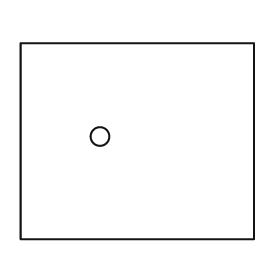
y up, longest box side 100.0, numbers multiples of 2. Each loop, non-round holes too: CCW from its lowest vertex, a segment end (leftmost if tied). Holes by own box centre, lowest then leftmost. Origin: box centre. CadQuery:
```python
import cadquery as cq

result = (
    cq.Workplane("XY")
    .moveTo(-50.0, -42.0)
    .lineTo(50.0, -42.0)
    .lineTo(50.0, 42.0)
    .lineTo(-50.0, 42.0)
    .close()
    .moveTo(-16.0, 2.0)
    .circle(4.0)
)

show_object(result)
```